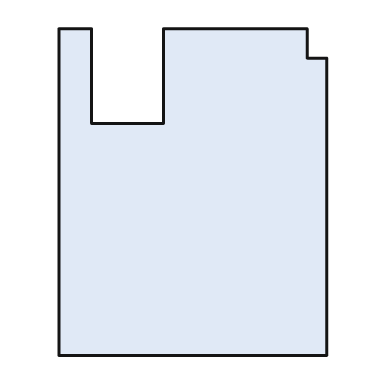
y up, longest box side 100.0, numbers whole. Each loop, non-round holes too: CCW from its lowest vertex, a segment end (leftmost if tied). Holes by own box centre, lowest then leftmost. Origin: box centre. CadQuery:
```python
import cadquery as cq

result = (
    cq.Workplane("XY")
    .moveTo(-41.0, -50.0)
    .lineTo(41.0, -50.0)
    .lineTo(41.0, 41.0)
    .lineTo(35.0, 41.0)
    .lineTo(35.0, 50.0)
    .lineTo(-9.0, 50.0)
    .lineTo(-9.0, 21.0)
    .lineTo(-31.0, 21.0)
    .lineTo(-31.0, 50.0)
    .lineTo(-41.0, 50.0)
    .close()
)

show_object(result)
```